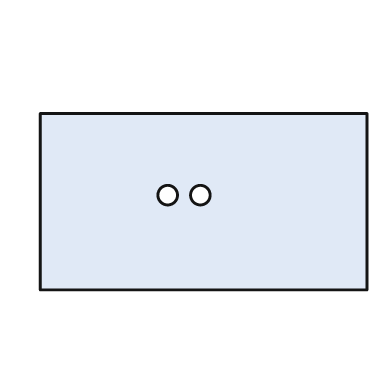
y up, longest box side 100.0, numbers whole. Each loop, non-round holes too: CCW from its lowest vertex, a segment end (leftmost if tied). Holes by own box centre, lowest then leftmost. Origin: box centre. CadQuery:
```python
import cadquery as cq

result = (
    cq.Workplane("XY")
    .moveTo(-50.0, -27.0)
    .lineTo(50.0, -27.0)
    .lineTo(50.0, 27.0)
    .lineTo(-50.0, 27.0)
    .close()
    .moveTo(-11.0, 2.0)
    .circle(3.0)
    .moveTo(-1.0, 2.0)
    .circle(3.0)
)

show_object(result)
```